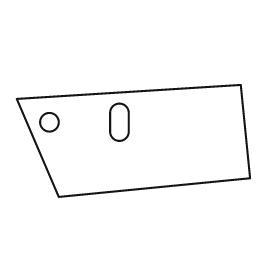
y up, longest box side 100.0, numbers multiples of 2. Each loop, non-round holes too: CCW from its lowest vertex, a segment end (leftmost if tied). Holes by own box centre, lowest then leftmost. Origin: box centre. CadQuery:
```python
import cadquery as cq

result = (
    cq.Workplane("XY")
    .moveTo(-32.0, -24.0)
    .lineTo(50.0, -16.0)
    .lineTo(46.0, 24.0)
    .lineTo(-50.0, 18.0)
    .close()
    .moveTo(-36.0, 8.0)
    .circle(4.0)
    .moveTo(-10.0, 4.0)
    .threePointArc((-6.0, 0.0), (-2.0, 4.0))
    .lineTo(-2.0, 12.0)
    .threePointArc((-6.0, 16.0), (-10.0, 12.0))
    .close()
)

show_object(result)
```